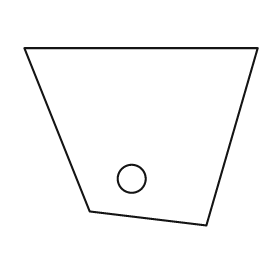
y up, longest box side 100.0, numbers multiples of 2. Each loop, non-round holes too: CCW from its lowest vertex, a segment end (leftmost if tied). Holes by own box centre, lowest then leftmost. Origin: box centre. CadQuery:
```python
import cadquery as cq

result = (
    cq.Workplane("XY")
    .moveTo(28.0, -38.0)
    .lineTo(50.0, 38.0)
    .lineTo(-50.0, 38.0)
    .lineTo(-22.0, -32.0)
    .close()
    .moveTo(-4.0, -18.0)
    .circle(6.0)
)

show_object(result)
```